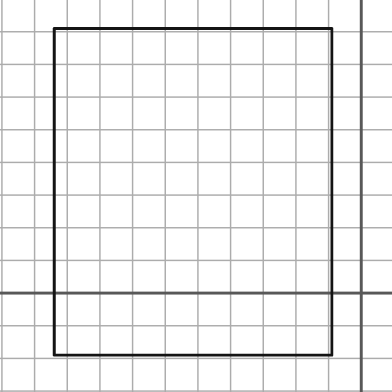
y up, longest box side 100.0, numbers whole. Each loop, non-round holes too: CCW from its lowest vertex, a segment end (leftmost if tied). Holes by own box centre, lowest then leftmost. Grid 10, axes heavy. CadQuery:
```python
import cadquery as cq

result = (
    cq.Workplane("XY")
    .moveTo(-94.0, -19.0)
    .lineTo(-9.0, -19.0)
    .lineTo(-9.0, 81.0)
    .lineTo(-94.0, 81.0)
    .close()
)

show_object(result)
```